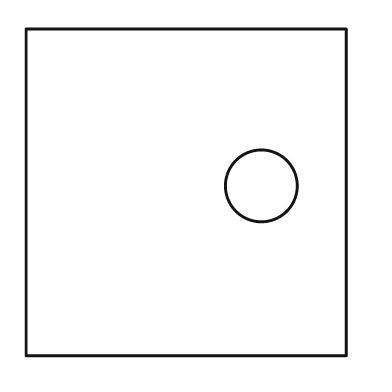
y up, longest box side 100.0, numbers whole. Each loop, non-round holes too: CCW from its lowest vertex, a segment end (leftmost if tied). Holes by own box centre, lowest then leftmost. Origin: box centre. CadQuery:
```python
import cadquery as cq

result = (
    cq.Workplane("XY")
    .moveTo(-49.0, -50.0)
    .lineTo(49.0, -50.0)
    .lineTo(49.0, 50.0)
    .lineTo(-49.0, 50.0)
    .close()
    .moveTo(23.0, 2.0)
    .circle(11.0)
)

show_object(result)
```